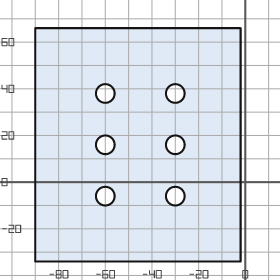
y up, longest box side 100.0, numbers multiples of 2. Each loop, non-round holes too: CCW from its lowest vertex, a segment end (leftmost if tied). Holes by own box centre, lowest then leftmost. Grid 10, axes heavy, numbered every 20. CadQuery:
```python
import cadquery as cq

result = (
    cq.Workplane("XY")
    .moveTo(-90.0, -34.0)
    .lineTo(-2.0, -34.0)
    .lineTo(-2.0, 66.0)
    .lineTo(-90.0, 66.0)
    .close()
    .moveTo(-60.0, -6.0)
    .circle(4.0)
    .moveTo(-30.0, -6.0)
    .circle(4.0)
    .moveTo(-60.0, 16.0)
    .circle(4.0)
    .moveTo(-30.0, 16.0)
    .circle(4.0)
    .moveTo(-60.0, 38.0)
    .circle(4.0)
    .moveTo(-30.0, 38.0)
    .circle(4.0)
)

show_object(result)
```